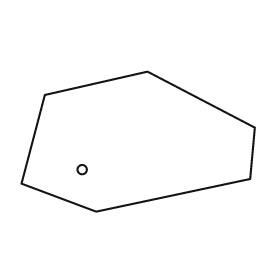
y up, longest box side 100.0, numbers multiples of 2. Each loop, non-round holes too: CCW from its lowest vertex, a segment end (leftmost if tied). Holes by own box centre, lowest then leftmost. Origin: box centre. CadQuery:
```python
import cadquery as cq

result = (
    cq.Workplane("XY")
    .moveTo(-18.0, -30.0)
    .lineTo(48.0, -16.0)
    .lineTo(50.0, 6.0)
    .lineTo(4.0, 30.0)
    .lineTo(-40.0, 20.0)
    .lineTo(-50.0, -18.0)
    .close()
    .moveTo(-24.0, -12.0)
    .circle(2.0)
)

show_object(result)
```